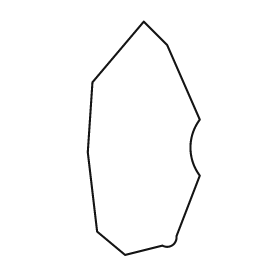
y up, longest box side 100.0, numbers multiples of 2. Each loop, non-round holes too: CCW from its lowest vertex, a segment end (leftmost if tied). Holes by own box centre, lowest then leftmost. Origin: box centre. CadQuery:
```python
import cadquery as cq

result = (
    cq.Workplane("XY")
    .moveTo(-8.0, -50.0)
    .lineTo(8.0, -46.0)
    .threePointArc((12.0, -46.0), (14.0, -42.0))
    .lineTo(24.0, -16.0)
    .threePointArc((20.0, -4.0), (24.0, 8.0))
    .lineTo(10.0, 40.0)
    .lineTo(0.0, 50.0)
    .lineTo(-22.0, 24.0)
    .lineTo(-24.0, -6.0)
    .lineTo(-20.0, -40.0)
    .close()
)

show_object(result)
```